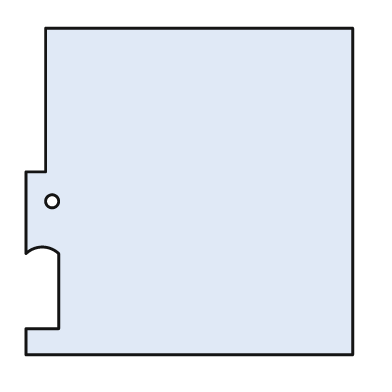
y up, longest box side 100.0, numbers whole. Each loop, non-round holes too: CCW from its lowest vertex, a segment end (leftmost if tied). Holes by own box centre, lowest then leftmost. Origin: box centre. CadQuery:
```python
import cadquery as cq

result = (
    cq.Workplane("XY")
    .moveTo(-50.0, -50.0)
    .lineTo(50.0, -50.0)
    .lineTo(50.0, 50.0)
    .lineTo(-44.0, 50.0)
    .lineTo(-44.0, 6.0)
    .lineTo(-50.0, 6.0)
    .lineTo(-50.0, -19.0)
    .threePointArc((-45.0, -17.0), (-40.0, -19.0))
    .lineTo(-40.0, -42.0)
    .lineTo(-50.0, -42.0)
    .close()
    .moveTo(-42.0, -3.0)
    .circle(2.0)
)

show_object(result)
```